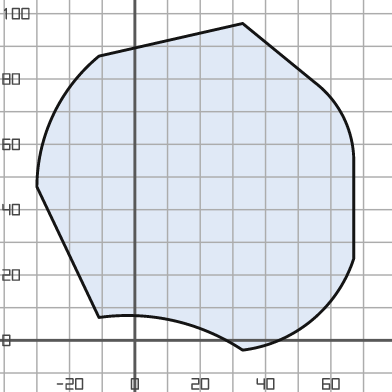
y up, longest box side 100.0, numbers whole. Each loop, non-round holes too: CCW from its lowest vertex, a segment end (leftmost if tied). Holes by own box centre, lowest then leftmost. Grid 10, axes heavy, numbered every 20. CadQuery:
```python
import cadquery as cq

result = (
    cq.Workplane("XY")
    .moveTo(33.0, -3.0)
    .threePointArc((54.0, 6.0), (67.0, 25.0))
    .lineTo(67.0, 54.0)
    .threePointArc((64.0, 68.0), (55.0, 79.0))
    .lineTo(33.0, 97.0)
    .lineTo(-11.0, 87.0)
    .threePointArc((-25.0, 69.0), (-30.0, 47.0))
    .lineTo(-11.0, 7.0)
    .threePointArc((12.0, 6.0), (33.0, -3.0))
    .close()
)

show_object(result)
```